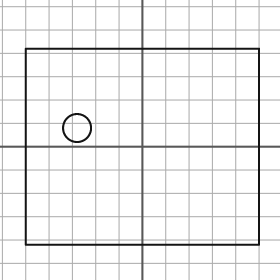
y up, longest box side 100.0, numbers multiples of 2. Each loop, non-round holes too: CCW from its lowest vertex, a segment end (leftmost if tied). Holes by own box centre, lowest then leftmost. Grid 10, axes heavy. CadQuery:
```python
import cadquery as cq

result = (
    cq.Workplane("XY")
    .moveTo(-50.0, -42.0)
    .lineTo(50.0, -42.0)
    .lineTo(50.0, 42.0)
    .lineTo(-50.0, 42.0)
    .close()
    .moveTo(-28.0, 8.0)
    .circle(6.0)
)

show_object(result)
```